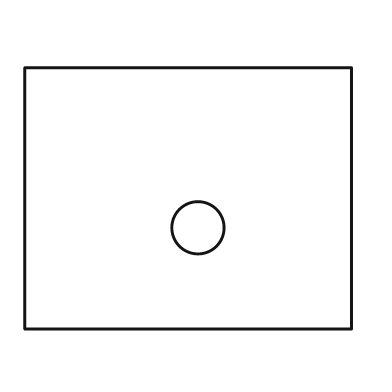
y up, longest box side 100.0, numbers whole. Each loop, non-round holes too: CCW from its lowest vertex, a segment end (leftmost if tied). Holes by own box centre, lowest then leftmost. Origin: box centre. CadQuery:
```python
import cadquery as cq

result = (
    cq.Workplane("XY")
    .moveTo(-50.0, -40.0)
    .lineTo(50.0, -40.0)
    .lineTo(50.0, 40.0)
    .lineTo(-50.0, 40.0)
    .close()
    .moveTo(3.0, -9.0)
    .circle(8.0)
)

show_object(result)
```